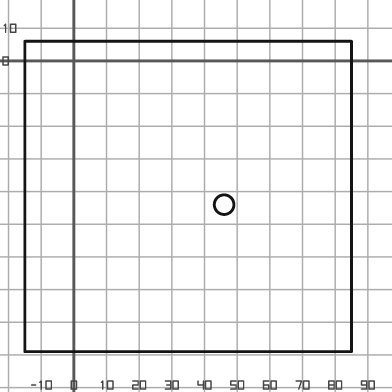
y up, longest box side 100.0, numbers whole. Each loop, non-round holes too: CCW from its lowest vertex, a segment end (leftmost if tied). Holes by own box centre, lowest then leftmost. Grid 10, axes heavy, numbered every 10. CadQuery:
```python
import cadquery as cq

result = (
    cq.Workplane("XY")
    .moveTo(-15.0, -89.0)
    .lineTo(85.0, -89.0)
    .lineTo(85.0, 6.0)
    .lineTo(-15.0, 6.0)
    .close()
    .moveTo(46.0, -44.0)
    .circle(3.0)
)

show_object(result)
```